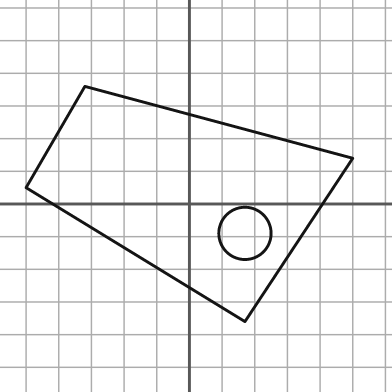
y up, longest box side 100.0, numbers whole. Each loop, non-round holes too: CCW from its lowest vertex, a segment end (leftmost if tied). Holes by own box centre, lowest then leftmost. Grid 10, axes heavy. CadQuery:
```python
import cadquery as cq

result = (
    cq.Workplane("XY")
    .moveTo(17.0, -36.0)
    .lineTo(50.0, 14.0)
    .lineTo(-32.0, 36.0)
    .lineTo(-50.0, 5.0)
    .close()
    .moveTo(17.0, -9.0)
    .circle(8.0)
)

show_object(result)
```